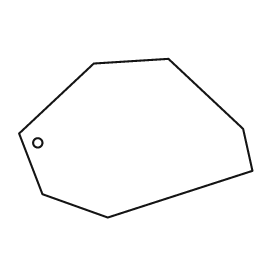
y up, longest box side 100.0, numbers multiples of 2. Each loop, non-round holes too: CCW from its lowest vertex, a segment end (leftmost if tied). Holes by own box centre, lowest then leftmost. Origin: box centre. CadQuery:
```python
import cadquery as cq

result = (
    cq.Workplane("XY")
    .moveTo(-12.0, -34.0)
    .lineTo(50.0, -14.0)
    .lineTo(46.0, 4.0)
    .lineTo(14.0, 34.0)
    .lineTo(-18.0, 32.0)
    .lineTo(-50.0, 2.0)
    .lineTo(-40.0, -24.0)
    .close()
    .moveTo(-42.0, -2.0)
    .circle(2.0)
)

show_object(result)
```